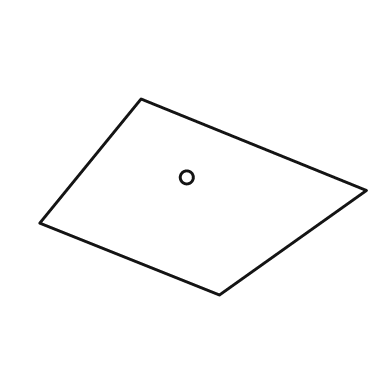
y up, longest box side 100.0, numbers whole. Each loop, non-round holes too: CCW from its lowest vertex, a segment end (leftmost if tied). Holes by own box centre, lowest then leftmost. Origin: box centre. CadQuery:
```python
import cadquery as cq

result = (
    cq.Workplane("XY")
    .moveTo(5.0, -30.0)
    .lineTo(50.0, 2.0)
    .lineTo(-19.0, 30.0)
    .lineTo(-50.0, -8.0)
    .close()
    .moveTo(-5.0, 6.0)
    .circle(2.0)
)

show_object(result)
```